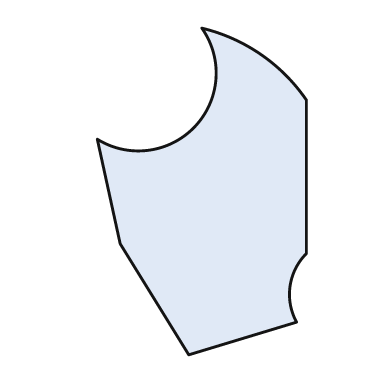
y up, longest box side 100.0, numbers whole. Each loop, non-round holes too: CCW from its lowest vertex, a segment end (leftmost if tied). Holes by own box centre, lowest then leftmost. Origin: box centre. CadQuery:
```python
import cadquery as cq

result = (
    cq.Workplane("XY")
    .moveTo(-4.0, -50.0)
    .lineTo(29.0, -40.0)
    .threePointArc((27.0, -29.0), (32.0, -19.0))
    .lineTo(32.0, 28.0)
    .threePointArc((18.0, 42.0), (0.0, 50.0))
    .threePointArc((-2.0, 20.0), (-32.0, 16.0))
    .lineTo(-25.0, -16.0)
    .close()
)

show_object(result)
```